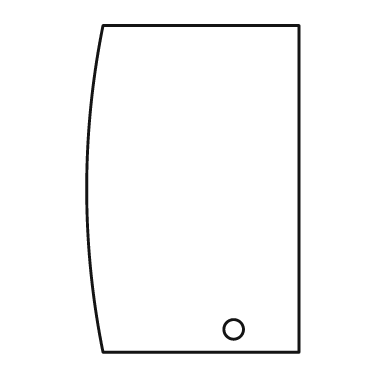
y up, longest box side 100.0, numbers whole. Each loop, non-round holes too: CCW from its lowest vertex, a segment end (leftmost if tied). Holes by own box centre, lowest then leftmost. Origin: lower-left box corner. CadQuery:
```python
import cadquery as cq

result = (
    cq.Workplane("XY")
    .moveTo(5.0, 0.0)
    .lineTo(65.0, 0.0)
    .lineTo(65.0, 100.0)
    .lineTo(5.0, 100.0)
    .threePointArc((0.0, 50.0), (5.0, 0.0))
    .close()
    .moveTo(45.0, 7.0)
    .circle(3.0)
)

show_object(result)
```